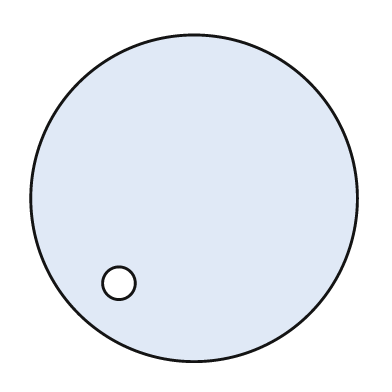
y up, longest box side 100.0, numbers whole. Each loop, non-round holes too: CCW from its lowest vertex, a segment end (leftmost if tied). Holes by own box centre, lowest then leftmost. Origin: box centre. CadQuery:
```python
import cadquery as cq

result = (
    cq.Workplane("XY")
    .moveTo(0.0, 0.0)
    .circle(50.0)
    .moveTo(-23.0, -26.0)
    .circle(5.0)
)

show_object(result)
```